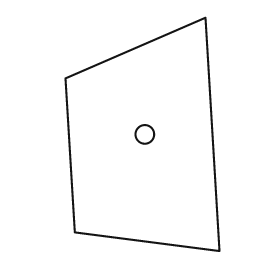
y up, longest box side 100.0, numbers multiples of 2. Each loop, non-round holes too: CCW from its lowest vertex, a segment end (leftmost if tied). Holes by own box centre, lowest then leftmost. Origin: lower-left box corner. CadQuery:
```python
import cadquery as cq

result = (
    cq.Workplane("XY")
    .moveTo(66.0, 0.0)
    .lineTo(60.0, 100.0)
    .lineTo(0.0, 74.0)
    .lineTo(4.0, 8.0)
    .close()
    .moveTo(34.0, 50.0)
    .circle(4.0)
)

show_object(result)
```